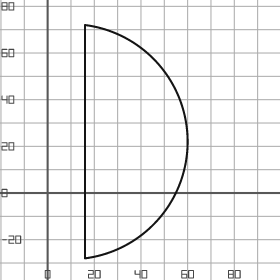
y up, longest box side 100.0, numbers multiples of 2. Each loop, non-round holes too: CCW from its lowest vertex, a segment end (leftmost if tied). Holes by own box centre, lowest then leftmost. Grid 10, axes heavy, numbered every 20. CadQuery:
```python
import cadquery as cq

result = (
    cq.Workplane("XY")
    .moveTo(16.0, -28.0)
    .threePointArc((60.0, 22.0), (16.0, 72.0))
    .close()
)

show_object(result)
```